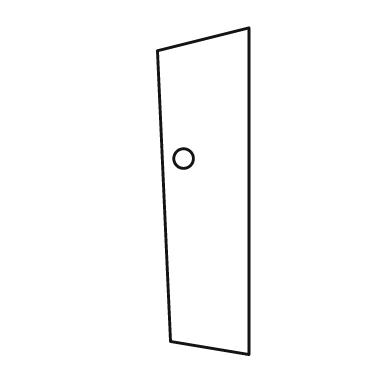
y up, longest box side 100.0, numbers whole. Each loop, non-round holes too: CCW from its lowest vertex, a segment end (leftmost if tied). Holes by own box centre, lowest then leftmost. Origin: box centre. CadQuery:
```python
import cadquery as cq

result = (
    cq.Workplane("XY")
    .moveTo(14.0, -50.0)
    .lineTo(14.0, 50.0)
    .lineTo(-14.0, 43.0)
    .lineTo(-10.0, -46.0)
    .close()
    .moveTo(-6.0, 10.0)
    .circle(3.0)
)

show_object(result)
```